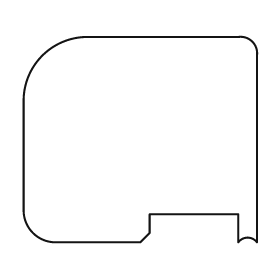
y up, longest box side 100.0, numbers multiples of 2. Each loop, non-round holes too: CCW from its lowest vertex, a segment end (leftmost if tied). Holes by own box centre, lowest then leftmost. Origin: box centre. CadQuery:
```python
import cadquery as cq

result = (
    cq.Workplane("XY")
    .moveTo(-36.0, -44.0)
    .lineTo(0.0, -44.0)
    .lineTo(4.0, -40.0)
    .lineTo(4.0, -32.0)
    .lineTo(42.0, -32.0)
    .lineTo(42.0, -44.0)
    .threePointArc((46.0, -42.0), (50.0, -44.0))
    .lineTo(50.0, 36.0)
    .threePointArc((48.0, 42.0), (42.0, 44.0))
    .lineTo(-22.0, 44.0)
    .threePointArc((-42.0, 36.0), (-50.0, 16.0))
    .lineTo(-50.0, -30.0)
    .threePointArc((-46.0, -40.0), (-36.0, -44.0))
    .close()
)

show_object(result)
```